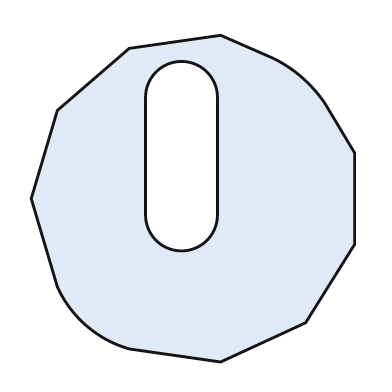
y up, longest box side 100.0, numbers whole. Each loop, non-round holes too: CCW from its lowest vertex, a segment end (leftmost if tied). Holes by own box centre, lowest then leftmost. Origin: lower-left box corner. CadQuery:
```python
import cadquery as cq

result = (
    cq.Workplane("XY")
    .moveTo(58.0, 0.0)
    .lineTo(84.0, 12.0)
    .lineTo(99.0, 36.0)
    .lineTo(99.0, 64.0)
    .lineTo(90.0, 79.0)
    .threePointArc((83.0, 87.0), (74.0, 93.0))
    .lineTo(58.0, 100.0)
    .lineTo(30.0, 96.0)
    .lineTo(8.0, 77.0)
    .lineTo(0.0, 50.0)
    .lineTo(8.0, 23.0)
    .threePointArc((17.0, 11.0), (30.0, 4.0))
    .close()
    .moveTo(35.0, 45.0)
    .threePointArc((46.0, 34.0), (57.0, 45.0))
    .lineTo(57.0, 81.0)
    .threePointArc((46.0, 92.0), (35.0, 81.0))
    .close()
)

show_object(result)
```